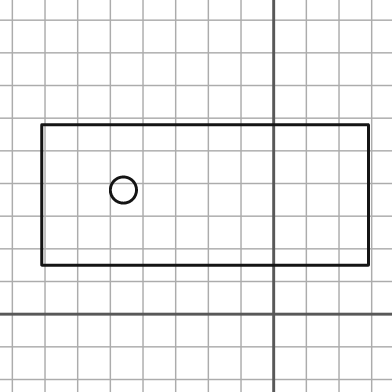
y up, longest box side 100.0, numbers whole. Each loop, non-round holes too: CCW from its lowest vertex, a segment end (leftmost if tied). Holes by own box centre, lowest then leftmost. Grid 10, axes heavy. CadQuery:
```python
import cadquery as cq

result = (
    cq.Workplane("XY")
    .moveTo(-71.0, 15.0)
    .lineTo(29.0, 15.0)
    .lineTo(29.0, 58.0)
    .lineTo(-71.0, 58.0)
    .close()
    .moveTo(-46.0, 38.0)
    .circle(4.0)
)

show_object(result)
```